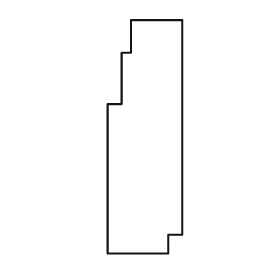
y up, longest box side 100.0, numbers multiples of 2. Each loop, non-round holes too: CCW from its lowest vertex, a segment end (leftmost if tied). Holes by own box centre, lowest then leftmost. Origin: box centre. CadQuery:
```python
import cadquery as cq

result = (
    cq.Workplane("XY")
    .moveTo(-16.0, -50.0)
    .lineTo(10.0, -50.0)
    .lineTo(10.0, -42.0)
    .lineTo(16.0, -42.0)
    .lineTo(16.0, 50.0)
    .lineTo(-6.0, 50.0)
    .lineTo(-6.0, 36.0)
    .lineTo(-10.0, 36.0)
    .lineTo(-10.0, 14.0)
    .lineTo(-16.0, 14.0)
    .close()
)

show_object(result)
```